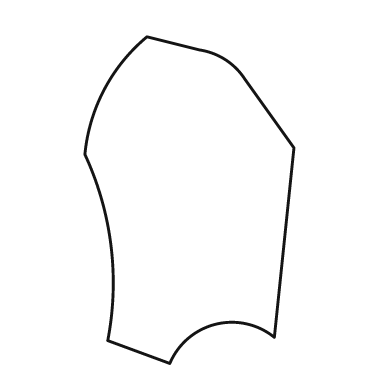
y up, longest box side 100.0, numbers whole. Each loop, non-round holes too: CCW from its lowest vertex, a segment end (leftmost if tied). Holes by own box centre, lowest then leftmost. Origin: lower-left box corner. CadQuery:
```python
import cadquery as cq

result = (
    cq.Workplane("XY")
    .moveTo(26.0, 0.0)
    .threePointArc((40.0, 12.0), (58.0, 8.0))
    .lineTo(64.0, 66.0)
    .lineTo(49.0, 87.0)
    .threePointArc((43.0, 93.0), (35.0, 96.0))
    .lineTo(19.0, 100.0)
    .threePointArc((6.0, 84.0), (0.0, 64.0))
    .threePointArc((8.0, 36.0), (7.0, 7.0))
    .close()
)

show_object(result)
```